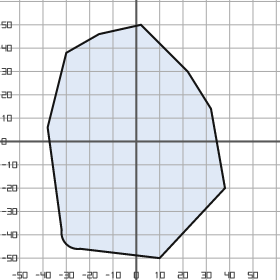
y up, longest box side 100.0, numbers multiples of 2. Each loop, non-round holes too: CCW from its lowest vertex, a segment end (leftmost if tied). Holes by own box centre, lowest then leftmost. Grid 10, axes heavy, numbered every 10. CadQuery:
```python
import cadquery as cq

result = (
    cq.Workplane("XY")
    .moveTo(10.0, -50.0)
    .lineTo(38.0, -20.0)
    .lineTo(32.0, 14.0)
    .lineTo(22.0, 30.0)
    .lineTo(2.0, 50.0)
    .lineTo(-16.0, 46.0)
    .lineTo(-30.0, 38.0)
    .lineTo(-38.0, 6.0)
    .lineTo(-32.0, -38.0)
    .threePointArc((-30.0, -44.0), (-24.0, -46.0))
    .close()
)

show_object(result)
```